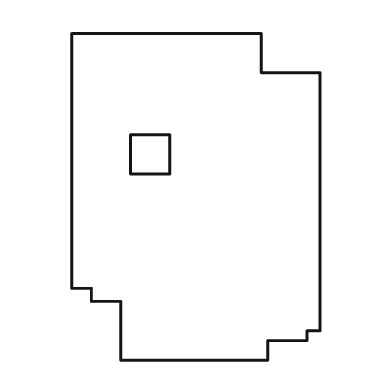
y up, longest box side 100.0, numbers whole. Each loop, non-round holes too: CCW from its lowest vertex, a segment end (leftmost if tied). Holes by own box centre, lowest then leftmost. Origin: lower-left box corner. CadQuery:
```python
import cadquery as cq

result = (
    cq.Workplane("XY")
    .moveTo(15.0, 0.0)
    .lineTo(60.0, 0.0)
    .lineTo(60.0, 6.0)
    .lineTo(72.0, 6.0)
    .lineTo(72.0, 9.0)
    .lineTo(76.0, 9.0)
    .lineTo(76.0, 88.0)
    .lineTo(58.0, 88.0)
    .lineTo(58.0, 100.0)
    .lineTo(0.0, 100.0)
    .lineTo(0.0, 22.0)
    .lineTo(6.0, 22.0)
    .lineTo(6.0, 18.0)
    .lineTo(15.0, 18.0)
    .close()
    .moveTo(18.0, 57.0)
    .lineTo(30.0, 57.0)
    .lineTo(30.0, 69.0)
    .lineTo(18.0, 69.0)
    .close()
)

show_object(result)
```